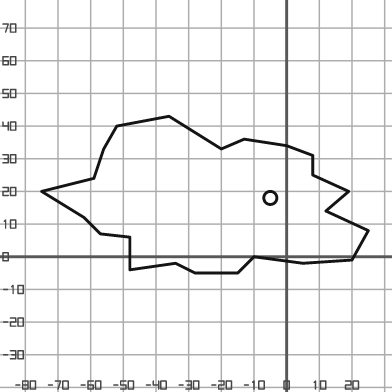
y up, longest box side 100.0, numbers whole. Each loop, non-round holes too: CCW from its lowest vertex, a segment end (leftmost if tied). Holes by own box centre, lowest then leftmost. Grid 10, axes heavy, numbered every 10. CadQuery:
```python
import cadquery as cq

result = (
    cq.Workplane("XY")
    .moveTo(-28.0, -5.0)
    .lineTo(-15.0, -5.0)
    .lineTo(-10.0, 0.0)
    .lineTo(5.0, -2.0)
    .lineTo(20.0, -1.0)
    .lineTo(25.0, 8.0)
    .lineTo(12.0, 14.0)
    .lineTo(19.0, 20.0)
    .lineTo(8.0, 25.0)
    .lineTo(8.0, 31.0)
    .lineTo(0.0, 34.0)
    .lineTo(-13.0, 36.0)
    .lineTo(-20.0, 33.0)
    .lineTo(-36.0, 43.0)
    .lineTo(-52.0, 40.0)
    .lineTo(-56.0, 33.0)
    .lineTo(-59.0, 24.0)
    .lineTo(-75.0, 20.0)
    .lineTo(-62.0, 12.0)
    .lineTo(-57.0, 7.0)
    .lineTo(-48.0, 6.0)
    .lineTo(-48.0, -4.0)
    .lineTo(-34.0, -2.0)
    .close()
    .moveTo(-5.0, 18.0)
    .circle(2.0)
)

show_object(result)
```